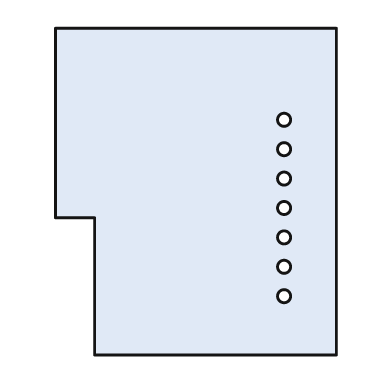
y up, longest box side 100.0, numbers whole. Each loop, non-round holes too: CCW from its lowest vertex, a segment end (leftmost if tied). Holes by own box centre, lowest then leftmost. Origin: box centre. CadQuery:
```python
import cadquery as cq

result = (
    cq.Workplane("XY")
    .moveTo(-31.0, -50.0)
    .lineTo(43.0, -50.0)
    .lineTo(43.0, 50.0)
    .lineTo(-43.0, 50.0)
    .lineTo(-43.0, -8.0)
    .lineTo(-31.0, -8.0)
    .close()
    .moveTo(27.0, -32.0)
    .circle(2.0)
    .moveTo(27.0, -23.0)
    .circle(2.0)
    .moveTo(27.0, -14.0)
    .circle(2.0)
    .moveTo(27.0, -5.0)
    .circle(2.0)
    .moveTo(27.0, 4.0)
    .circle(2.0)
    .moveTo(27.0, 13.0)
    .circle(2.0)
    .moveTo(27.0, 22.0)
    .circle(2.0)
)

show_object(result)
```